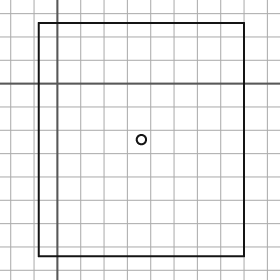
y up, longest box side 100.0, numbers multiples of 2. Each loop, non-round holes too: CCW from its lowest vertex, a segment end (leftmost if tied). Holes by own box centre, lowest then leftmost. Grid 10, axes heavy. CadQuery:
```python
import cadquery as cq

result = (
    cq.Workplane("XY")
    .moveTo(-8.0, -74.0)
    .lineTo(80.0, -74.0)
    .lineTo(80.0, 26.0)
    .lineTo(-8.0, 26.0)
    .close()
    .moveTo(36.0, -24.0)
    .circle(2.0)
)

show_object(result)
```